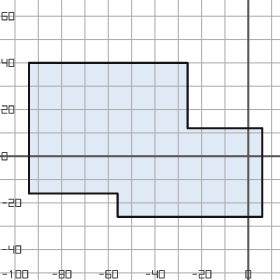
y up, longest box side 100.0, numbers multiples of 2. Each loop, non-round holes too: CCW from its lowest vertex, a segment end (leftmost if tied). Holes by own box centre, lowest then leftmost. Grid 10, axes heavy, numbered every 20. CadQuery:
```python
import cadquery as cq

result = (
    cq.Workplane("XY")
    .moveTo(-56.0, -26.0)
    .lineTo(6.0, -26.0)
    .lineTo(6.0, 12.0)
    .lineTo(-26.0, 12.0)
    .lineTo(-26.0, 40.0)
    .lineTo(-94.0, 40.0)
    .lineTo(-94.0, -16.0)
    .lineTo(-56.0, -16.0)
    .close()
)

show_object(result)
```